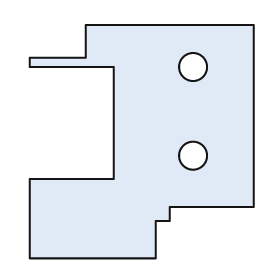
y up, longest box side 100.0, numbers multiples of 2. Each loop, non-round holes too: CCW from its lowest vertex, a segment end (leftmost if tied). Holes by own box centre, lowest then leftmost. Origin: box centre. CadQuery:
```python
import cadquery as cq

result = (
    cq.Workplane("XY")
    .moveTo(-48.0, -50.0)
    .lineTo(6.0, -50.0)
    .lineTo(6.0, -34.0)
    .lineTo(12.0, -34.0)
    .lineTo(12.0, -28.0)
    .lineTo(48.0, -28.0)
    .lineTo(48.0, 50.0)
    .lineTo(-24.0, 50.0)
    .lineTo(-24.0, 36.0)
    .lineTo(-48.0, 36.0)
    .lineTo(-48.0, 32.0)
    .lineTo(-12.0, 32.0)
    .lineTo(-12.0, -16.0)
    .lineTo(-48.0, -16.0)
    .close()
    .moveTo(22.0, -6.0)
    .circle(6.0)
    .moveTo(22.0, 32.0)
    .circle(6.0)
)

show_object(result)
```